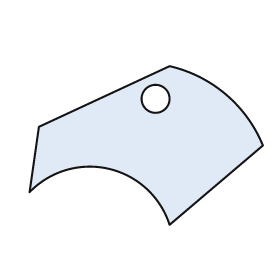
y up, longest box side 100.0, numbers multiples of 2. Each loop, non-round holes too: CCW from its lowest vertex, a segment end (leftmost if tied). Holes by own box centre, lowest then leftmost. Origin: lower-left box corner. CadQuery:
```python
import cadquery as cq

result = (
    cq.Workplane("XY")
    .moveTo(60.0, 0.0)
    .lineTo(100.0, 34.0)
    .threePointArc((84.0, 56.0), (60.0, 68.0))
    .lineTo(4.0, 42.0)
    .lineTo(0.0, 14.0)
    .threePointArc((34.0, 24.0), (60.0, 0.0))
    .close()
    .moveTo(54.0, 54.0)
    .circle(6.0)
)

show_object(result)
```